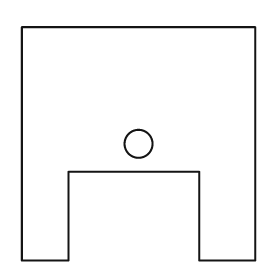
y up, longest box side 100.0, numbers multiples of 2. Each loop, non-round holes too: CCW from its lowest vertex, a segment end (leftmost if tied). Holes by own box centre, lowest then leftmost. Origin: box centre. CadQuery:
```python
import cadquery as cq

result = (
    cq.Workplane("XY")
    .moveTo(-50.0, -50.0)
    .lineTo(-30.0, -50.0)
    .lineTo(-30.0, -12.0)
    .lineTo(26.0, -12.0)
    .lineTo(26.0, -50.0)
    .lineTo(50.0, -50.0)
    .lineTo(50.0, 50.0)
    .lineTo(-50.0, 50.0)
    .close()
    .moveTo(0.0, 0.0)
    .circle(6.0)
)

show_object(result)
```